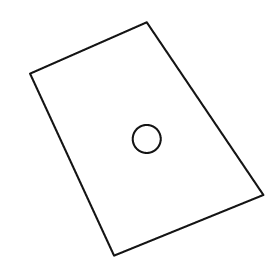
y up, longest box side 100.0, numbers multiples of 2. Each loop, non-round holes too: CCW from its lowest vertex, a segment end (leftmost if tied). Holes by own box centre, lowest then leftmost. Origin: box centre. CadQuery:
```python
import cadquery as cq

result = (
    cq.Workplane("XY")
    .moveTo(-14.0, -50.0)
    .lineTo(50.0, -24.0)
    .lineTo(0.0, 50.0)
    .lineTo(-50.0, 28.0)
    .close()
    .moveTo(0.0, 0.0)
    .circle(6.0)
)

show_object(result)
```